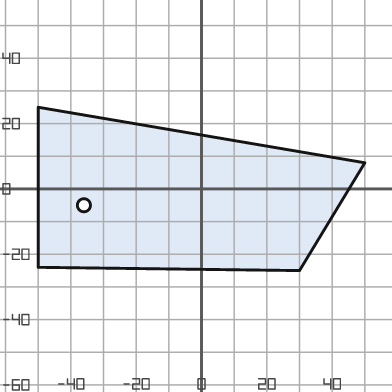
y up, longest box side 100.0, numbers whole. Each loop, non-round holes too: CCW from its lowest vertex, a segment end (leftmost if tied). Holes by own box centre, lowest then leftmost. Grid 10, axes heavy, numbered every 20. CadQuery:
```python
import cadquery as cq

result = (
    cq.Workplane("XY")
    .moveTo(30.0, -25.0)
    .lineTo(50.0, 8.0)
    .lineTo(-50.0, 25.0)
    .lineTo(-50.0, -24.0)
    .close()
    .moveTo(-36.0, -5.0)
    .circle(2.0)
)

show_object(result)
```